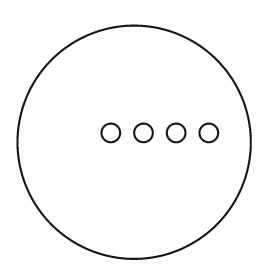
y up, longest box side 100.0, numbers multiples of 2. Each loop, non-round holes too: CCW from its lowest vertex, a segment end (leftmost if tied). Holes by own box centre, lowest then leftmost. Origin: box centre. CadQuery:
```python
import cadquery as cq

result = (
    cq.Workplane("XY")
    .moveTo(0.0, 0.0)
    .circle(50.0)
    .moveTo(-10.0, 4.0)
    .circle(4.0)
    .moveTo(4.0, 4.0)
    .circle(4.0)
    .moveTo(18.0, 4.0)
    .circle(4.0)
    .moveTo(32.0, 4.0)
    .circle(4.0)
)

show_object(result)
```